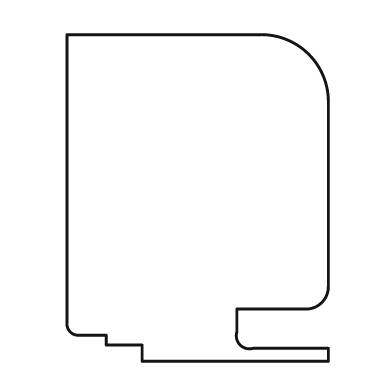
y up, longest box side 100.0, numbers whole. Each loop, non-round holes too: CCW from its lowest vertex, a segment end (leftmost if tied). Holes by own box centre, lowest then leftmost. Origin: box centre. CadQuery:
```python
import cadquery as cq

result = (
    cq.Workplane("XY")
    .moveTo(-17.0, -50.0)
    .lineTo(40.0, -50.0)
    .lineTo(40.0, -46.0)
    .lineTo(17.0, -46.0)
    .threePointArc((13.0, -45.0), (12.0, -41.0))
    .lineTo(12.0, -34.0)
    .lineTo(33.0, -34.0)
    .threePointArc((38.0, -32.0), (40.0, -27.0))
    .lineTo(40.0, 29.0)
    .threePointArc((34.0, 44.0), (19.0, 50.0))
    .lineTo(-40.0, 50.0)
    .lineTo(-40.0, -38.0)
    .threePointArc((-39.0, -41.0), (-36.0, -42.0))
    .lineTo(-28.0, -42.0)
    .lineTo(-28.0, -45.0)
    .lineTo(-17.0, -45.0)
    .close()
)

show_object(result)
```